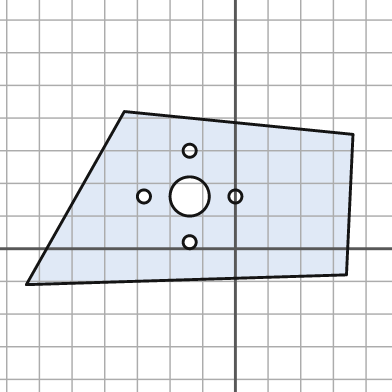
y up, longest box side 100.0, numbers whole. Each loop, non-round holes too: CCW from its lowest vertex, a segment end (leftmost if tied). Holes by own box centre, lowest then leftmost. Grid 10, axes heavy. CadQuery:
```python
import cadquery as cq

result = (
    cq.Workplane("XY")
    .moveTo(-64.0, -11.0)
    .lineTo(34.0, -8.0)
    .lineTo(36.0, 35.0)
    .lineTo(-34.0, 42.0)
    .close()
    .moveTo(-14.0, 2.0)
    .circle(2.0)
    .moveTo(-28.0, 16.0)
    .circle(2.0)
    .moveTo(-14.0, 16.0)
    .circle(6.0)
    .moveTo(0.0, 16.0)
    .circle(2.0)
    .moveTo(-14.0, 30.0)
    .circle(2.0)
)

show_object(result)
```